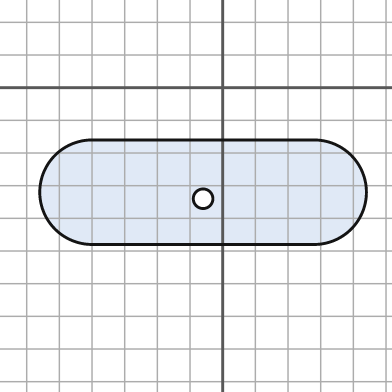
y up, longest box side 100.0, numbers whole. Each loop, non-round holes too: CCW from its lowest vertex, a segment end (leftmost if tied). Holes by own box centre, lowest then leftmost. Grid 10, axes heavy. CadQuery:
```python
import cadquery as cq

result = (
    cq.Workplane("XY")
    .moveTo(-40.0, -48.0)
    .lineTo(28.0, -48.0)
    .threePointArc((44.0, -32.0), (28.0, -16.0))
    .lineTo(-40.0, -16.0)
    .threePointArc((-56.0, -32.0), (-40.0, -48.0))
    .close()
    .moveTo(-6.0, -34.0)
    .circle(3.0)
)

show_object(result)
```